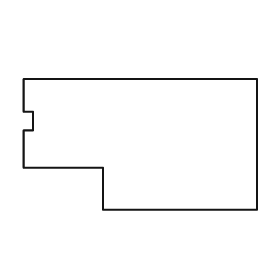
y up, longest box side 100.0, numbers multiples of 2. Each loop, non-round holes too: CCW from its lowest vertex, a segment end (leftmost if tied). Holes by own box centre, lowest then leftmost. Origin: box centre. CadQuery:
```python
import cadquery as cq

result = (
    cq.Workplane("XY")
    .moveTo(-16.0, -28.0)
    .lineTo(50.0, -28.0)
    .lineTo(50.0, 28.0)
    .lineTo(-50.0, 28.0)
    .lineTo(-50.0, 14.0)
    .lineTo(-46.0, 14.0)
    .lineTo(-46.0, 6.0)
    .lineTo(-50.0, 6.0)
    .lineTo(-50.0, -10.0)
    .lineTo(-16.0, -10.0)
    .close()
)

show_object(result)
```